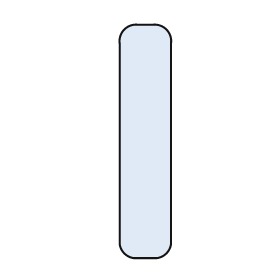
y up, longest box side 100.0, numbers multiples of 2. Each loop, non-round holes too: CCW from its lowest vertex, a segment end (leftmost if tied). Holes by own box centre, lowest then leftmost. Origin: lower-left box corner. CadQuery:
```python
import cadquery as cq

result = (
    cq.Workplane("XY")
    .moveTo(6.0, 0.0)
    .lineTo(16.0, 0.0)
    .threePointArc((20.0, 2.0), (22.0, 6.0))
    .lineTo(22.0, 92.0)
    .threePointArc((20.0, 98.0), (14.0, 100.0))
    .lineTo(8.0, 100.0)
    .threePointArc((2.0, 98.0), (0.0, 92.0))
    .lineTo(0.0, 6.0)
    .threePointArc((2.0, 2.0), (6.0, 0.0))
    .close()
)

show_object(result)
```